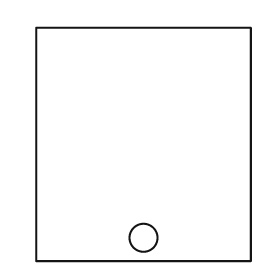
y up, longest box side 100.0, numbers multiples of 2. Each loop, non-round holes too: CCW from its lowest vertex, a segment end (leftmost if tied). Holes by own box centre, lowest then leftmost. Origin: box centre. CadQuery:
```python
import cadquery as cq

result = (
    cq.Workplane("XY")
    .moveTo(-46.0, -50.0)
    .lineTo(46.0, -50.0)
    .lineTo(46.0, 50.0)
    .lineTo(-46.0, 50.0)
    .close()
    .moveTo(0.0, -40.0)
    .circle(6.0)
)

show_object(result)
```